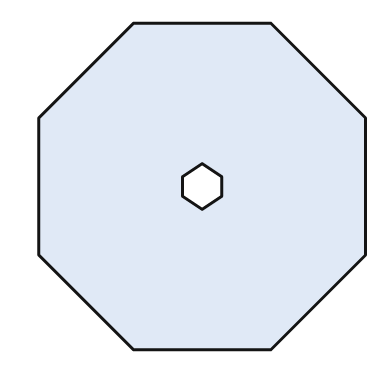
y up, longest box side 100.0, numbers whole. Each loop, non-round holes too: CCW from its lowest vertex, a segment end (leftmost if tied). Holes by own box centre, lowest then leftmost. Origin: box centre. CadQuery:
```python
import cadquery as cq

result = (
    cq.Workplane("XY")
    .moveTo(-21.0, -50.0)
    .lineTo(21.0, -50.0)
    .lineTo(50.0, -21.0)
    .lineTo(50.0, 21.0)
    .lineTo(21.0, 50.0)
    .lineTo(-21.0, 50.0)
    .lineTo(-50.0, 21.0)
    .lineTo(-50.0, -21.0)
    .close()
    .moveTo(0.0, -7.0)
    .lineTo(6.0, -3.0)
    .lineTo(6.0, 3.0)
    .lineTo(0.0, 7.0)
    .lineTo(-6.0, 3.0)
    .lineTo(-6.0, -3.0)
    .close()
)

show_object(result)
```